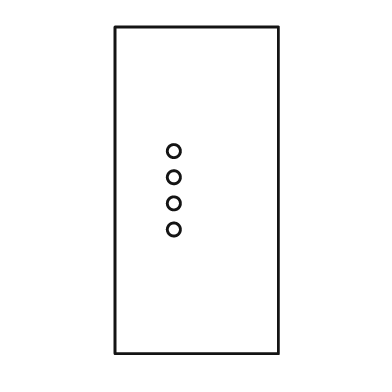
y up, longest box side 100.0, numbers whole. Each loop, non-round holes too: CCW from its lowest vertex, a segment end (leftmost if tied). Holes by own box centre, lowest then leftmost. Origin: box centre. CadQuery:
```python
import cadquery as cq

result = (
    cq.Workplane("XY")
    .moveTo(-25.0, -50.0)
    .lineTo(25.0, -50.0)
    .lineTo(25.0, 50.0)
    .lineTo(-25.0, 50.0)
    .close()
    .moveTo(-7.0, -12.0)
    .circle(2.0)
    .moveTo(-7.0, -4.0)
    .circle(2.0)
    .moveTo(-7.0, 4.0)
    .circle(2.0)
    .moveTo(-7.0, 12.0)
    .circle(2.0)
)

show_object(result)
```